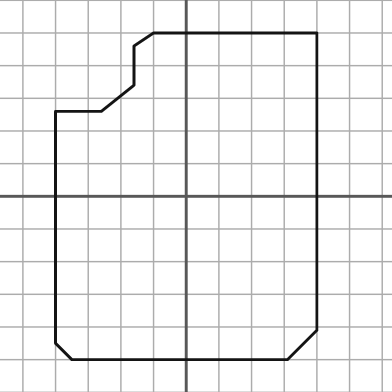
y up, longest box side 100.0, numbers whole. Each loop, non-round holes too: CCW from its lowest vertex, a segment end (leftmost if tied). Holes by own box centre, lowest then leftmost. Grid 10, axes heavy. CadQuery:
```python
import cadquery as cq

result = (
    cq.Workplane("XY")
    .moveTo(-35.0, -50.0)
    .lineTo(31.0, -50.0)
    .lineTo(40.0, -41.0)
    .lineTo(40.0, 50.0)
    .lineTo(-10.0, 50.0)
    .lineTo(-16.0, 46.0)
    .lineTo(-16.0, 34.0)
    .lineTo(-26.0, 26.0)
    .lineTo(-40.0, 26.0)
    .lineTo(-40.0, -45.0)
    .close()
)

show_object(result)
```